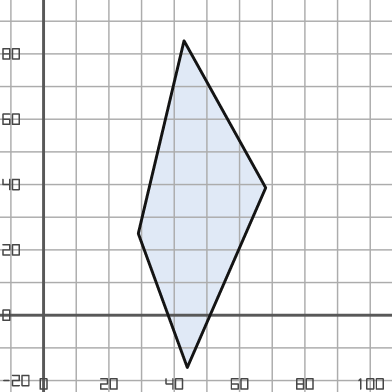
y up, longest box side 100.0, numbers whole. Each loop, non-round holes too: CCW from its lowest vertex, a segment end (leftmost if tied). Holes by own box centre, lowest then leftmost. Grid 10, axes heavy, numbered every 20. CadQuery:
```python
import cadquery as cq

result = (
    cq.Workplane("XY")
    .moveTo(44.0, -16.0)
    .lineTo(68.0, 39.0)
    .lineTo(43.0, 84.0)
    .lineTo(29.0, 25.0)
    .close()
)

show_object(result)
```